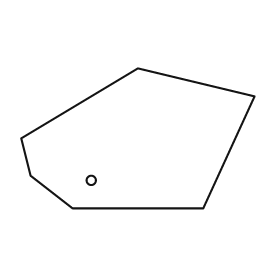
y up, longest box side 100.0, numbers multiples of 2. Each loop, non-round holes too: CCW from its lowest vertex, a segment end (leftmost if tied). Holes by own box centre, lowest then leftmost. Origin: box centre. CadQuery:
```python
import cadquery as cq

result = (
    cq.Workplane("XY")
    .moveTo(-28.0, -30.0)
    .lineTo(28.0, -30.0)
    .lineTo(50.0, 18.0)
    .lineTo(0.0, 30.0)
    .lineTo(-50.0, 0.0)
    .lineTo(-46.0, -16.0)
    .close()
    .moveTo(-20.0, -18.0)
    .circle(2.0)
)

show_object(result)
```